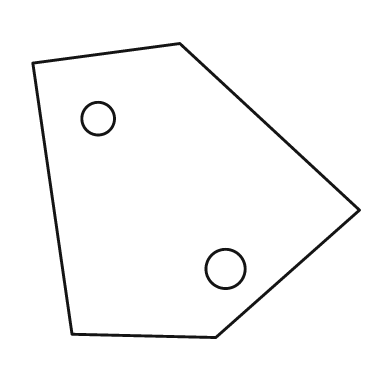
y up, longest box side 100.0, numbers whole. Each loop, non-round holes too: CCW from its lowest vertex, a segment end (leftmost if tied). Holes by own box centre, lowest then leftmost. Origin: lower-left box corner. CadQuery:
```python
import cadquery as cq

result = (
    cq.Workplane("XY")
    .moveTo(56.0, 0.0)
    .lineTo(100.0, 39.0)
    .lineTo(45.0, 90.0)
    .lineTo(0.0, 84.0)
    .lineTo(12.0, 1.0)
    .close()
    .moveTo(59.0, 21.0)
    .circle(6.0)
    .moveTo(20.0, 67.0)
    .circle(5.0)
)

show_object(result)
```